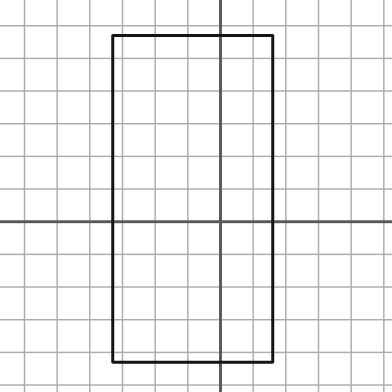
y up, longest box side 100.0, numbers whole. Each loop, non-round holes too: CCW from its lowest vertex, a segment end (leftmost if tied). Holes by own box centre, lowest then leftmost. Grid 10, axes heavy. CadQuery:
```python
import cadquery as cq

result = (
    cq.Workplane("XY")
    .moveTo(-33.0, -43.0)
    .lineTo(16.0, -43.0)
    .lineTo(16.0, 57.0)
    .lineTo(-33.0, 57.0)
    .close()
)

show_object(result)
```